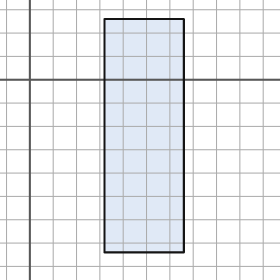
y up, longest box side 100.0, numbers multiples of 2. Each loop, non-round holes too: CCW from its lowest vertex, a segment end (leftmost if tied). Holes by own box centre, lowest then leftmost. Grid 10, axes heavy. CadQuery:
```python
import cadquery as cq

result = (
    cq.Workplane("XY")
    .moveTo(32.0, -74.0)
    .lineTo(66.0, -74.0)
    .lineTo(66.0, 26.0)
    .lineTo(32.0, 26.0)
    .close()
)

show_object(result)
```